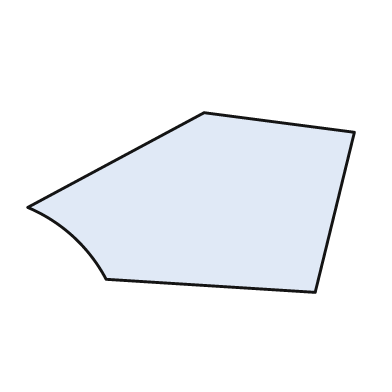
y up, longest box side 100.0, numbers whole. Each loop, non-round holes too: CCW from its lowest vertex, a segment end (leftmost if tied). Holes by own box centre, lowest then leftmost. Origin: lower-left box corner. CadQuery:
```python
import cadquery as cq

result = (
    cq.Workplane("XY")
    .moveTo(88.0, 0.0)
    .lineTo(100.0, 49.0)
    .lineTo(54.0, 55.0)
    .lineTo(0.0, 26.0)
    .threePointArc((14.0, 17.0), (24.0, 4.0))
    .close()
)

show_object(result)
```